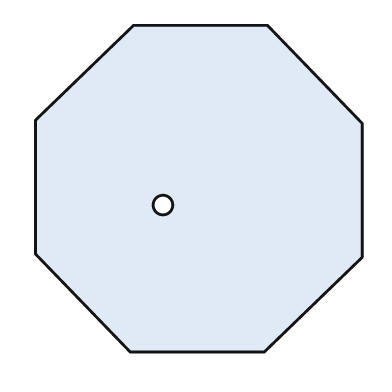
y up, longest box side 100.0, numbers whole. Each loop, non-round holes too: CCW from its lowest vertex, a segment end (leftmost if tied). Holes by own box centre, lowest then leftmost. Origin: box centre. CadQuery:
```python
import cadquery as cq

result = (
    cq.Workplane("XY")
    .moveTo(-21.0, -50.0)
    .lineTo(20.0, -50.0)
    .lineTo(50.0, -21.0)
    .lineTo(50.0, 20.0)
    .lineTo(21.0, 50.0)
    .lineTo(-20.0, 50.0)
    .lineTo(-50.0, 21.0)
    .lineTo(-50.0, -20.0)
    .close()
    .moveTo(-11.0, -5.0)
    .circle(3.0)
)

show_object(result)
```